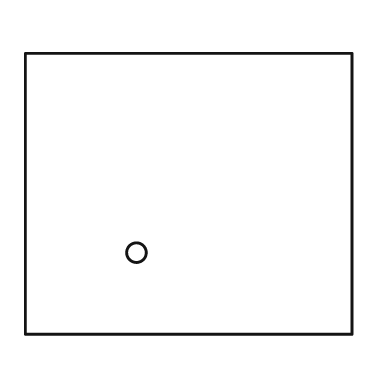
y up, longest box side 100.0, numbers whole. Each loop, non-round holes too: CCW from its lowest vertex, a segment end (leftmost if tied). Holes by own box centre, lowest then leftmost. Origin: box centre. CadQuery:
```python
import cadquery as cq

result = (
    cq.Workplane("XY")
    .moveTo(-50.0, -43.0)
    .lineTo(50.0, -43.0)
    .lineTo(50.0, 43.0)
    .lineTo(-50.0, 43.0)
    .close()
    .moveTo(-16.0, -18.0)
    .circle(3.0)
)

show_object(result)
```